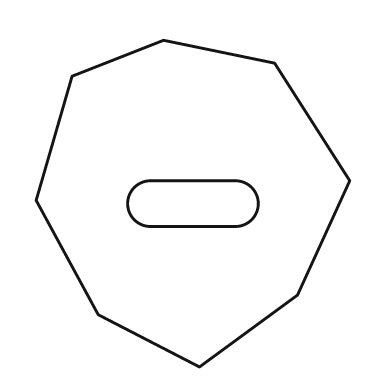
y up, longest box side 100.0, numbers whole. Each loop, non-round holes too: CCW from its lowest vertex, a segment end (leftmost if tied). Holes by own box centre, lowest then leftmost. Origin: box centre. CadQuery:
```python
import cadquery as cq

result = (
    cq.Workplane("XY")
    .moveTo(2.0, -50.0)
    .lineTo(32.0, -28.0)
    .lineTo(48.0, 7.0)
    .lineTo(25.0, 43.0)
    .lineTo(-9.0, 50.0)
    .lineTo(-37.0, 39.0)
    .lineTo(-48.0, 1.0)
    .lineTo(-29.0, -34.0)
    .close()
    .moveTo(-13.0, -7.0)
    .lineTo(13.0, -7.0)
    .threePointArc((20.0, 0.0), (13.0, 7.0))
    .lineTo(-13.0, 7.0)
    .threePointArc((-20.0, 0.0), (-13.0, -7.0))
    .close()
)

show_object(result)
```